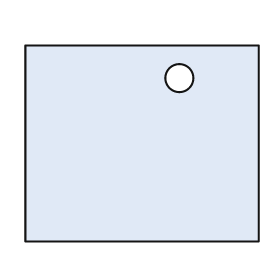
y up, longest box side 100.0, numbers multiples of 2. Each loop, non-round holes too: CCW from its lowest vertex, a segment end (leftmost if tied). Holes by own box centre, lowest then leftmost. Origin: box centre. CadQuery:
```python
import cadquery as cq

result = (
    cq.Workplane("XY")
    .moveTo(-50.0, -42.0)
    .lineTo(50.0, -42.0)
    .lineTo(50.0, 42.0)
    .lineTo(-50.0, 42.0)
    .close()
    .moveTo(16.0, 28.0)
    .circle(6.0)
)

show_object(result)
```